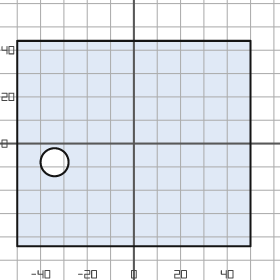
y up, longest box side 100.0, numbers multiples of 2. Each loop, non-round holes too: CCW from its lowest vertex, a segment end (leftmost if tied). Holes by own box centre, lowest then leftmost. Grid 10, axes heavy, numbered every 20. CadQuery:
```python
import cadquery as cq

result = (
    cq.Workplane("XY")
    .moveTo(-50.0, -44.0)
    .lineTo(50.0, -44.0)
    .lineTo(50.0, 44.0)
    .lineTo(-50.0, 44.0)
    .close()
    .moveTo(-34.0, -8.0)
    .circle(6.0)
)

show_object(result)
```